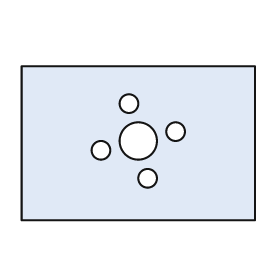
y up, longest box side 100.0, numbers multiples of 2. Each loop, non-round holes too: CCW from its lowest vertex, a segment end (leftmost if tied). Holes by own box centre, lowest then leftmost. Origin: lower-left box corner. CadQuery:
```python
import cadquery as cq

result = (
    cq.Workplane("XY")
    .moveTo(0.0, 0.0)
    .lineTo(100.0, 0.0)
    .lineTo(100.0, 66.0)
    .lineTo(0.0, 66.0)
    .close()
    .moveTo(54.0, 18.0)
    .circle(4.0)
    .moveTo(34.0, 30.0)
    .circle(4.0)
    .moveTo(50.0, 34.0)
    .circle(8.0)
    .moveTo(66.0, 38.0)
    .circle(4.0)
    .moveTo(46.0, 50.0)
    .circle(4.0)
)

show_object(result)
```